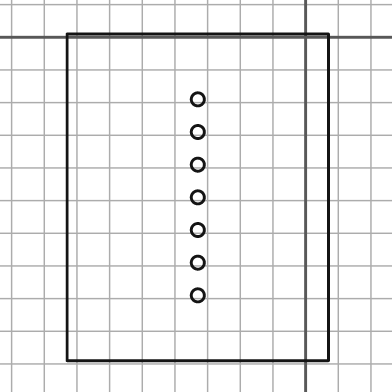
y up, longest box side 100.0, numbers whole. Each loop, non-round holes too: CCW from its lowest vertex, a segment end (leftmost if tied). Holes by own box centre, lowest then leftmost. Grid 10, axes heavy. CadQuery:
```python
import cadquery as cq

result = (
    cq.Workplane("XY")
    .moveTo(-73.0, -99.0)
    .lineTo(7.0, -99.0)
    .lineTo(7.0, 1.0)
    .lineTo(-73.0, 1.0)
    .close()
    .moveTo(-33.0, -79.0)
    .circle(2.0)
    .moveTo(-33.0, -69.0)
    .circle(2.0)
    .moveTo(-33.0, -59.0)
    .circle(2.0)
    .moveTo(-33.0, -49.0)
    .circle(2.0)
    .moveTo(-33.0, -39.0)
    .circle(2.0)
    .moveTo(-33.0, -29.0)
    .circle(2.0)
    .moveTo(-33.0, -19.0)
    .circle(2.0)
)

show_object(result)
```